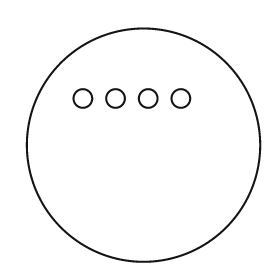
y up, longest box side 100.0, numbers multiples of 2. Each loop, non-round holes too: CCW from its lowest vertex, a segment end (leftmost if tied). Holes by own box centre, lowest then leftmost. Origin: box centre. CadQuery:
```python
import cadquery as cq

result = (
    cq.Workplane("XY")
    .moveTo(0.0, 0.0)
    .circle(50.0)
    .moveTo(-26.0, 20.0)
    .circle(4.0)
    .moveTo(-12.0, 20.0)
    .circle(4.0)
    .moveTo(2.0, 20.0)
    .circle(4.0)
    .moveTo(16.0, 20.0)
    .circle(4.0)
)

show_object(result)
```